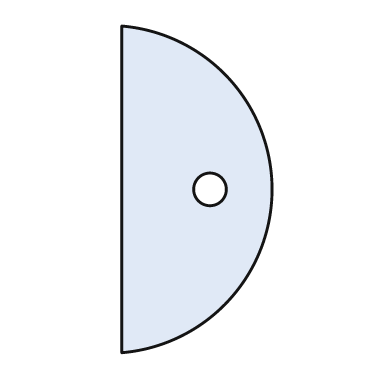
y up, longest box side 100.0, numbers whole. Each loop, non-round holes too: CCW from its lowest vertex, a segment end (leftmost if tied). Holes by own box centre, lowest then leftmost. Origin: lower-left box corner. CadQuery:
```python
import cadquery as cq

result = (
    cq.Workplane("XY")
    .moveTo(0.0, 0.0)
    .threePointArc((46.0, 50.0), (0.0, 100.0))
    .close()
    .moveTo(27.0, 50.0)
    .circle(5.0)
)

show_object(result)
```